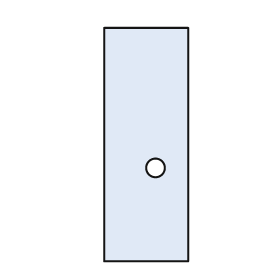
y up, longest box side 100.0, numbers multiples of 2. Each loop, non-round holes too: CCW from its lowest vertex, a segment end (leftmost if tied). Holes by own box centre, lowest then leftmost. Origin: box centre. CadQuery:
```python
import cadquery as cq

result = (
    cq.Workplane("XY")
    .moveTo(-18.0, -50.0)
    .lineTo(18.0, -50.0)
    .lineTo(18.0, 50.0)
    .lineTo(-18.0, 50.0)
    .close()
    .moveTo(4.0, -10.0)
    .circle(4.0)
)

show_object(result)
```